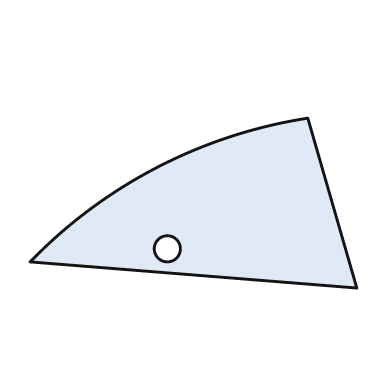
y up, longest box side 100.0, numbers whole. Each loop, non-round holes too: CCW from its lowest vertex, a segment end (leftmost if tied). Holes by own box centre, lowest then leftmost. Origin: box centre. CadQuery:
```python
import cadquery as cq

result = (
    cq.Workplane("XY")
    .moveTo(50.0, -26.0)
    .lineTo(35.0, 26.0)
    .threePointArc((-11.0, 11.0), (-50.0, -18.0))
    .close()
    .moveTo(-8.0, -14.0)
    .circle(4.0)
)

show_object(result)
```